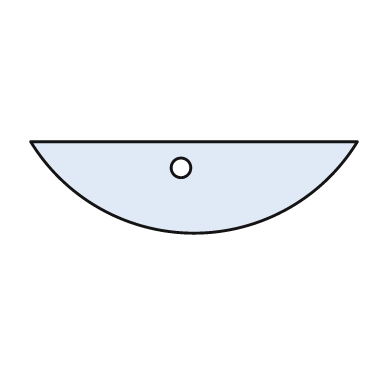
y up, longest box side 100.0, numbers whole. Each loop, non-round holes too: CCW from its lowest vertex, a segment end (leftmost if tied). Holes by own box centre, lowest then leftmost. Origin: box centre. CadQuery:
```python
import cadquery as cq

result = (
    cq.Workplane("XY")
    .moveTo(-50.0, 14.0)
    .threePointArc((0.0, -14.0), (50.0, 14.0))
    .close()
    .moveTo(-4.0, 6.0)
    .circle(3.0)
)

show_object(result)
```